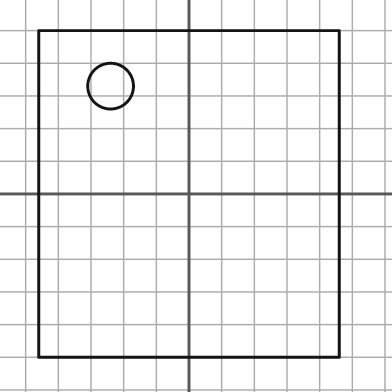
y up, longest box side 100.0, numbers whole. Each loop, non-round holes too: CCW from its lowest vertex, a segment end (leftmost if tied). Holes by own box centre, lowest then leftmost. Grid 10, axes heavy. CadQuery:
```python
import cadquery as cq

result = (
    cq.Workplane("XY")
    .moveTo(-46.0, -50.0)
    .lineTo(46.0, -50.0)
    .lineTo(46.0, 50.0)
    .lineTo(-46.0, 50.0)
    .close()
    .moveTo(-24.0, 33.0)
    .circle(7.0)
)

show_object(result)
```